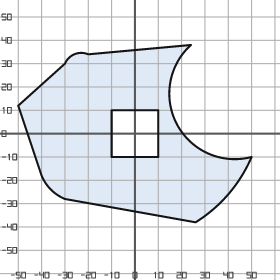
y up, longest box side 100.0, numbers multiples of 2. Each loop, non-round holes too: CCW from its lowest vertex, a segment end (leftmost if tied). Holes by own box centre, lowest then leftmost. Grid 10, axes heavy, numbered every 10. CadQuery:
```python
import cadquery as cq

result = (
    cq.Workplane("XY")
    .moveTo(26.0, -38.0)
    .threePointArc((40.0, -26.0), (50.0, -10.0))
    .threePointArc((18.0, 4.0), (24.0, 38.0))
    .lineTo(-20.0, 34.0)
    .threePointArc((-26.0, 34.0), (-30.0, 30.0))
    .lineTo(-50.0, 12.0)
    .lineTo(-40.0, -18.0)
    .threePointArc((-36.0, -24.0), (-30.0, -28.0))
    .close()
    .moveTo(-10.0, -10.0)
    .lineTo(10.0, -10.0)
    .lineTo(10.0, 10.0)
    .lineTo(-10.0, 10.0)
    .close()
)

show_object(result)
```